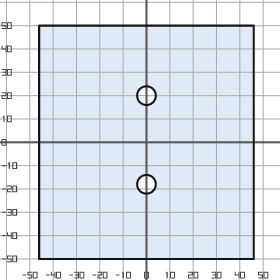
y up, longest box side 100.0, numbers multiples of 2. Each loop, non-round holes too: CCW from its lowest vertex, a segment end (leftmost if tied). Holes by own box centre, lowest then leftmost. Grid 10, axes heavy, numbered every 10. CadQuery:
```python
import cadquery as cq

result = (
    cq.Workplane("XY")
    .moveTo(-46.0, -50.0)
    .lineTo(46.0, -50.0)
    .lineTo(46.0, 50.0)
    .lineTo(-46.0, 50.0)
    .close()
    .moveTo(0.0, -18.0)
    .circle(4.0)
    .moveTo(0.0, 20.0)
    .circle(4.0)
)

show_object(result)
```